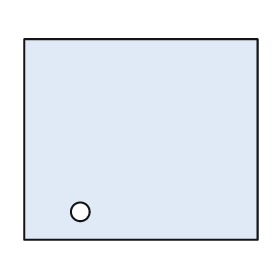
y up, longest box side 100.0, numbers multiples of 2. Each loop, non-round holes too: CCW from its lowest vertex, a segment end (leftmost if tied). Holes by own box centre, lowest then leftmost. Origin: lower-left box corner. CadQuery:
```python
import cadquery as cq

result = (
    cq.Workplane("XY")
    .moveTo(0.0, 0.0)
    .lineTo(100.0, 0.0)
    .lineTo(100.0, 86.0)
    .lineTo(0.0, 86.0)
    .close()
    .moveTo(24.0, 12.0)
    .circle(4.0)
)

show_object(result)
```